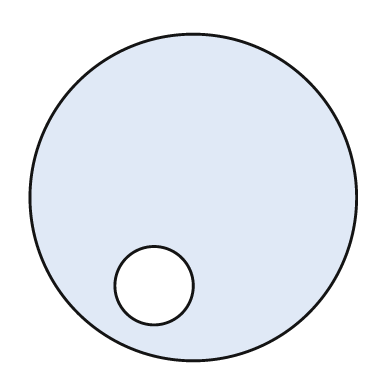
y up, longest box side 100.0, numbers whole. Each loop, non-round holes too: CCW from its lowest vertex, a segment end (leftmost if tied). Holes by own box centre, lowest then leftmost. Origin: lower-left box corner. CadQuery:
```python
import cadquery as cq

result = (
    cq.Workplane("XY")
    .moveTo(50.0, 50.0)
    .circle(50.0)
    .moveTo(38.0, 23.0)
    .circle(12.0)
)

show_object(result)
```